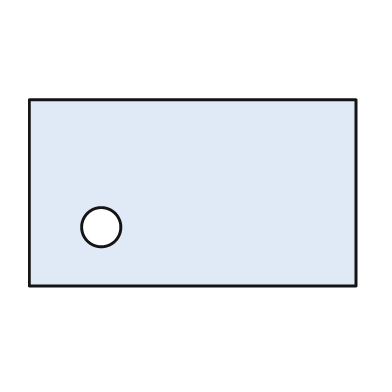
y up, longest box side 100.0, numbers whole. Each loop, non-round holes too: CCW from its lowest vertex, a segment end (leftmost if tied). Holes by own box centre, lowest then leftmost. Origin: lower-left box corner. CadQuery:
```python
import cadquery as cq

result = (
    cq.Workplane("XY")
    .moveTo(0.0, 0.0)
    .lineTo(100.0, 0.0)
    .lineTo(100.0, 57.0)
    .lineTo(0.0, 57.0)
    .close()
    .moveTo(22.0, 18.0)
    .circle(6.0)
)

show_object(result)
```